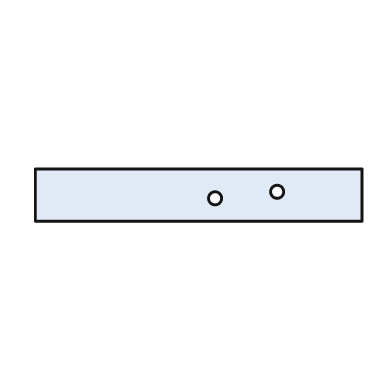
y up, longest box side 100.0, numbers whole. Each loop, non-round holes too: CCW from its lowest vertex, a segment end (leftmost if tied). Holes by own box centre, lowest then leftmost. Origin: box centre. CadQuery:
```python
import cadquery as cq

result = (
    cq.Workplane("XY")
    .moveTo(-50.0, -8.0)
    .lineTo(50.0, -8.0)
    .lineTo(50.0, 8.0)
    .lineTo(-50.0, 8.0)
    .close()
    .moveTo(5.0, -1.0)
    .circle(2.0)
    .moveTo(24.0, 1.0)
    .circle(2.0)
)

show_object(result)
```